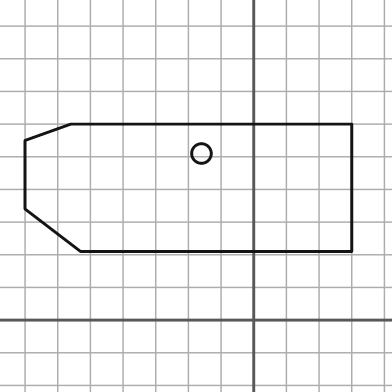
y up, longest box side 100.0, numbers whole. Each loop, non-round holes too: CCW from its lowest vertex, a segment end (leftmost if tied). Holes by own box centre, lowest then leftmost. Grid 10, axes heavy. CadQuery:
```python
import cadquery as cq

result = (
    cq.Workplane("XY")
    .moveTo(-53.0, 21.0)
    .lineTo(30.0, 21.0)
    .lineTo(30.0, 60.0)
    .lineTo(-56.0, 60.0)
    .lineTo(-70.0, 55.0)
    .lineTo(-70.0, 34.0)
    .close()
    .moveTo(-16.0, 51.0)
    .circle(3.0)
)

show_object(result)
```